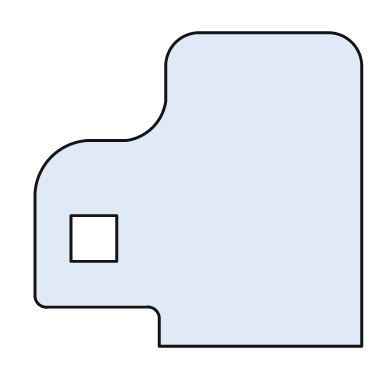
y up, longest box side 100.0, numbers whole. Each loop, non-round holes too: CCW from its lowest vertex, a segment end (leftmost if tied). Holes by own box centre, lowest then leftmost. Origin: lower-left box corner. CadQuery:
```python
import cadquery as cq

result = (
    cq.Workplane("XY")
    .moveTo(38.0, 0.0)
    .lineTo(100.0, 0.0)
    .lineTo(100.0, 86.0)
    .threePointArc((97.0, 93.0), (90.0, 96.0))
    .lineTo(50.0, 96.0)
    .threePointArc((43.0, 93.0), (40.0, 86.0))
    .lineTo(40.0, 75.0)
    .threePointArc((36.0, 67.0), (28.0, 63.0))
    .lineTo(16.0, 63.0)
    .threePointArc((5.0, 58.0), (0.0, 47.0))
    .lineTo(0.0, 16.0)
    .threePointArc((1.0, 13.0), (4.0, 12.0))
    .lineTo(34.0, 12.0)
    .threePointArc((37.0, 11.0), (38.0, 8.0))
    .close()
    .moveTo(11.0, 26.0)
    .lineTo(25.0, 26.0)
    .lineTo(25.0, 40.0)
    .lineTo(11.0, 40.0)
    .close()
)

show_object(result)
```